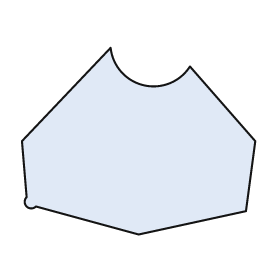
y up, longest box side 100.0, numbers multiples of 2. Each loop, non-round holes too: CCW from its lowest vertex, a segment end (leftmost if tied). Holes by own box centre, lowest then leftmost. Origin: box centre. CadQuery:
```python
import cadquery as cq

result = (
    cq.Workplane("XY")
    .moveTo(0.0, -40.0)
    .lineTo(46.0, -30.0)
    .lineTo(50.0, 0.0)
    .lineTo(22.0, 32.0)
    .threePointArc((2.0, 24.0), (-12.0, 40.0))
    .lineTo(-50.0, 0.0)
    .lineTo(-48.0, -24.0)
    .threePointArc((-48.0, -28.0), (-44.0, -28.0))
    .close()
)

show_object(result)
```